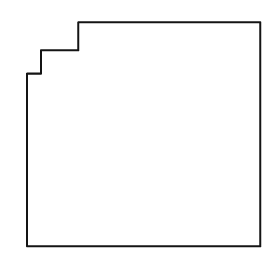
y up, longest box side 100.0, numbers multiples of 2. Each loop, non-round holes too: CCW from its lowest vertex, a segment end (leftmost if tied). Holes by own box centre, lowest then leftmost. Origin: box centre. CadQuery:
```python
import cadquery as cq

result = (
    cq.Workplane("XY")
    .moveTo(-50.0, -48.0)
    .lineTo(50.0, -48.0)
    .lineTo(50.0, 48.0)
    .lineTo(-28.0, 48.0)
    .lineTo(-28.0, 36.0)
    .lineTo(-44.0, 36.0)
    .lineTo(-44.0, 26.0)
    .lineTo(-50.0, 26.0)
    .close()
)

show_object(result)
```